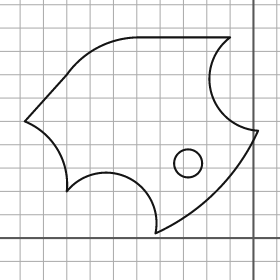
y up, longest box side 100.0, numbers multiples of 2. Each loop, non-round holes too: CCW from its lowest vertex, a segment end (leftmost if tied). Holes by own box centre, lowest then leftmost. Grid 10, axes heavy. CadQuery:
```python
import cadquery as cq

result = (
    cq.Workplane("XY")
    .moveTo(-42.0, 2.0)
    .threePointArc((-16.0, 20.0), (2.0, 46.0))
    .threePointArc((-18.0, 62.0), (-10.0, 86.0))
    .lineTo(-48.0, 86.0)
    .threePointArc((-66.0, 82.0), (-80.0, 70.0))
    .lineTo(-98.0, 50.0)
    .threePointArc((-84.0, 38.0), (-80.0, 20.0))
    .threePointArc((-54.0, 26.0), (-42.0, 2.0))
    .close()
    .moveTo(-28.0, 32.0)
    .circle(6.0)
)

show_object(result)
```